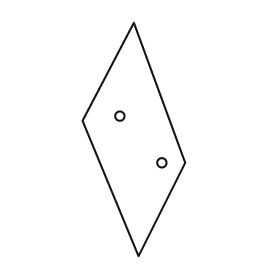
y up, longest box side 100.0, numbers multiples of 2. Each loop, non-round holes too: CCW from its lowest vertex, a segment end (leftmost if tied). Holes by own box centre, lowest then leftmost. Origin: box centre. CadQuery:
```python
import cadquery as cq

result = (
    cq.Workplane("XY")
    .moveTo(2.0, -50.0)
    .lineTo(22.0, -10.0)
    .lineTo(0.0, 50.0)
    .lineTo(-22.0, 8.0)
    .close()
    .moveTo(12.0, -10.0)
    .circle(2.0)
    .moveTo(-6.0, 10.0)
    .circle(2.0)
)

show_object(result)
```